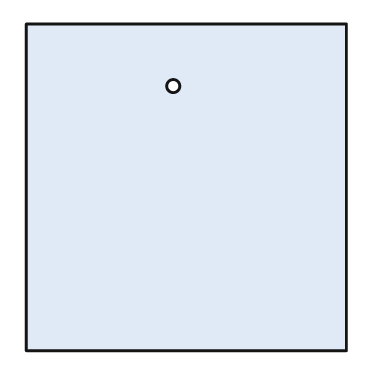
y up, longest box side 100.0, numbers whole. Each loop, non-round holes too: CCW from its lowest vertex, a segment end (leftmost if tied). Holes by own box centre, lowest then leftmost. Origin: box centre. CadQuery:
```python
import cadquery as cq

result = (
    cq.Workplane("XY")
    .moveTo(-49.0, -50.0)
    .lineTo(49.0, -50.0)
    .lineTo(49.0, 50.0)
    .lineTo(-49.0, 50.0)
    .close()
    .moveTo(-4.0, 31.0)
    .circle(2.0)
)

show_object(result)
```